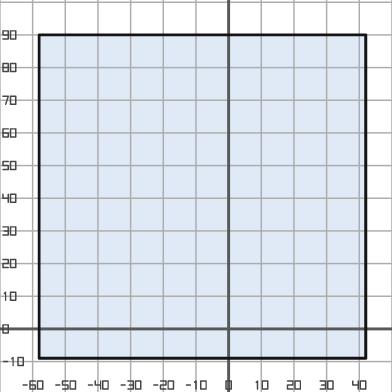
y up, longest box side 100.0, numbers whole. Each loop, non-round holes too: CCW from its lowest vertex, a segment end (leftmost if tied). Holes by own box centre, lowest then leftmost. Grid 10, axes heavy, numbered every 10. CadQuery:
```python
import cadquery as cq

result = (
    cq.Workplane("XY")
    .moveTo(-58.0, -9.0)
    .lineTo(42.0, -9.0)
    .lineTo(42.0, 90.0)
    .lineTo(-58.0, 90.0)
    .close()
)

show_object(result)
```